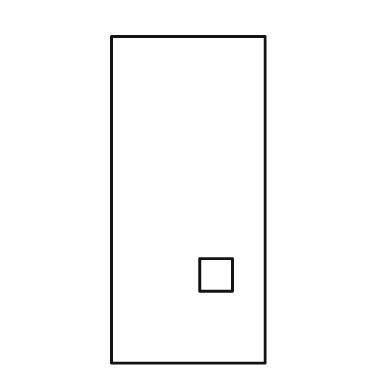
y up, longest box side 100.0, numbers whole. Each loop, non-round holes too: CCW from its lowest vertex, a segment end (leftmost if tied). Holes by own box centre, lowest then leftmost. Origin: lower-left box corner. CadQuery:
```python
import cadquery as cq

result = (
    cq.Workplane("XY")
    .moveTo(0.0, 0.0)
    .lineTo(47.0, 0.0)
    .lineTo(47.0, 100.0)
    .lineTo(0.0, 100.0)
    .close()
    .moveTo(27.0, 22.0)
    .lineTo(37.0, 22.0)
    .lineTo(37.0, 32.0)
    .lineTo(27.0, 32.0)
    .close()
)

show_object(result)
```